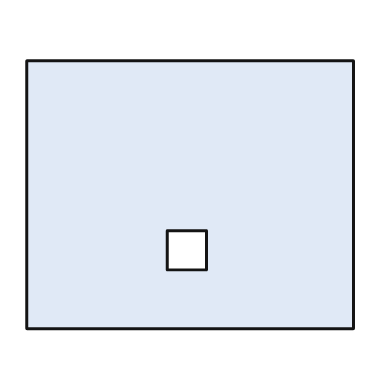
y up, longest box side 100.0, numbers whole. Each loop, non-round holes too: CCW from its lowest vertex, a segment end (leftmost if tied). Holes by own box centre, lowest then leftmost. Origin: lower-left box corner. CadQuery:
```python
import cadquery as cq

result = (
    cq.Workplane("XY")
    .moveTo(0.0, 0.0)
    .lineTo(100.0, 0.0)
    .lineTo(100.0, 82.0)
    .lineTo(0.0, 82.0)
    .close()
    .moveTo(43.0, 18.0)
    .lineTo(55.0, 18.0)
    .lineTo(55.0, 30.0)
    .lineTo(43.0, 30.0)
    .close()
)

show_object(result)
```